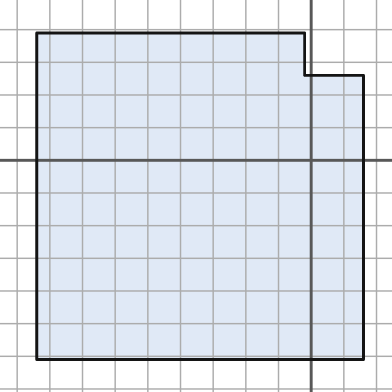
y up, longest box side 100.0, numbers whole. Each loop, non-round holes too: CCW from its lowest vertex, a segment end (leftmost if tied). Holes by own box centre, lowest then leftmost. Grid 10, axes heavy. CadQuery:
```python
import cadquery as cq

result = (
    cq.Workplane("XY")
    .moveTo(-84.0, -61.0)
    .lineTo(16.0, -61.0)
    .lineTo(16.0, 26.0)
    .lineTo(-2.0, 26.0)
    .lineTo(-2.0, 39.0)
    .lineTo(-84.0, 39.0)
    .close()
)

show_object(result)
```